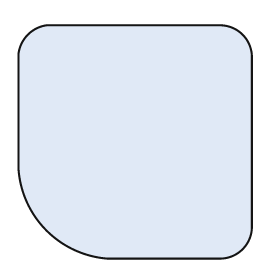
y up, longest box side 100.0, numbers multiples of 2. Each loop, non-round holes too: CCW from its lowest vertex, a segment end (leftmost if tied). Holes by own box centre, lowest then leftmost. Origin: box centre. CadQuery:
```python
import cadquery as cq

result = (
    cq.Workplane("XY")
    .moveTo(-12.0, -50.0)
    .lineTo(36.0, -50.0)
    .threePointArc((46.0, -46.0), (50.0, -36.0))
    .lineTo(50.0, 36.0)
    .threePointArc((46.0, 46.0), (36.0, 50.0))
    .lineTo(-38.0, 50.0)
    .threePointArc((-46.0, 46.0), (-50.0, 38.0))
    .lineTo(-50.0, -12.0)
    .threePointArc((-38.0, -38.0), (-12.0, -50.0))
    .close()
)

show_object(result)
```